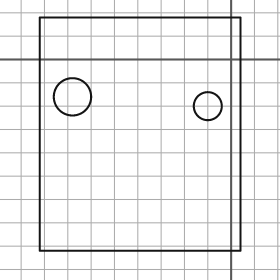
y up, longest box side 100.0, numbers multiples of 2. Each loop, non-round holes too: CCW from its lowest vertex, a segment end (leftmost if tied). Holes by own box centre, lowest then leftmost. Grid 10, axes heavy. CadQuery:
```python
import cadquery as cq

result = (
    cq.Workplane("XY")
    .moveTo(-82.0, -82.0)
    .lineTo(4.0, -82.0)
    .lineTo(4.0, 18.0)
    .lineTo(-82.0, 18.0)
    .close()
    .moveTo(-10.0, -20.0)
    .circle(6.0)
    .moveTo(-68.0, -16.0)
    .circle(8.0)
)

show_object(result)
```